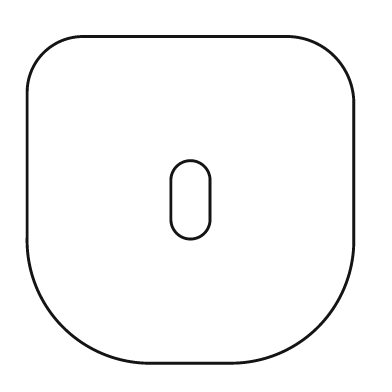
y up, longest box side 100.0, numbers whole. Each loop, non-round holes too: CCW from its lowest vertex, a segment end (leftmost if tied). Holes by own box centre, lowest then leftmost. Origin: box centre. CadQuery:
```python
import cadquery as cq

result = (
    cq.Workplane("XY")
    .moveTo(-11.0, -50.0)
    .lineTo(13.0, -50.0)
    .threePointArc((39.0, -39.0), (50.0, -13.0))
    .lineTo(50.0, 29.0)
    .threePointArc((44.0, 44.0), (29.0, 50.0))
    .lineTo(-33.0, 50.0)
    .threePointArc((-45.0, 45.0), (-50.0, 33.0))
    .lineTo(-50.0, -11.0)
    .threePointArc((-39.0, -39.0), (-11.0, -50.0))
    .close()
    .moveTo(-6.0, -6.0)
    .threePointArc((0.0, -12.0), (6.0, -6.0))
    .lineTo(6.0, 6.0)
    .threePointArc((0.0, 12.0), (-6.0, 6.0))
    .close()
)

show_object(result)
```